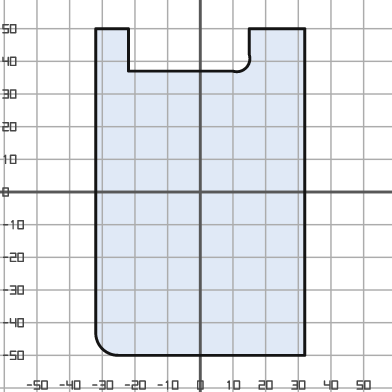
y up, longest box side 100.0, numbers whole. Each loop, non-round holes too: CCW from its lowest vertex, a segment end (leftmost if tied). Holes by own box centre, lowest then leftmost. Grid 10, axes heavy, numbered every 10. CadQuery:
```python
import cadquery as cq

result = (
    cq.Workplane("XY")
    .moveTo(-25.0, -50.0)
    .lineTo(32.0, -50.0)
    .lineTo(32.0, 50.0)
    .lineTo(15.0, 50.0)
    .lineTo(15.0, 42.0)
    .threePointArc((14.0, 38.0), (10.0, 37.0))
    .lineTo(-22.0, 37.0)
    .lineTo(-22.0, 50.0)
    .lineTo(-32.0, 50.0)
    .lineTo(-32.0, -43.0)
    .threePointArc((-30.0, -48.0), (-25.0, -50.0))
    .close()
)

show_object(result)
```